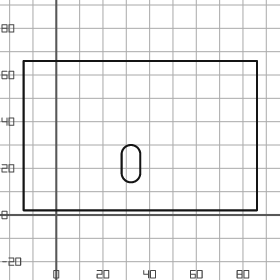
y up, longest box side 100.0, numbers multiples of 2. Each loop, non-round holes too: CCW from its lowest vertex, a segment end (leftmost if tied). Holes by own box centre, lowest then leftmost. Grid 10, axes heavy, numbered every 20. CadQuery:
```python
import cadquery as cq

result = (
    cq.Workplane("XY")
    .moveTo(-14.0, 2.0)
    .lineTo(86.0, 2.0)
    .lineTo(86.0, 66.0)
    .lineTo(-14.0, 66.0)
    .close()
    .moveTo(28.0, 18.0)
    .threePointArc((32.0, 14.0), (36.0, 18.0))
    .lineTo(36.0, 26.0)
    .threePointArc((32.0, 30.0), (28.0, 26.0))
    .close()
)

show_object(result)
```